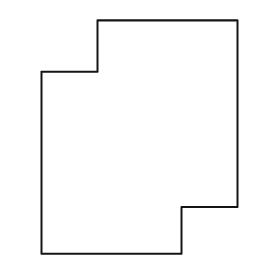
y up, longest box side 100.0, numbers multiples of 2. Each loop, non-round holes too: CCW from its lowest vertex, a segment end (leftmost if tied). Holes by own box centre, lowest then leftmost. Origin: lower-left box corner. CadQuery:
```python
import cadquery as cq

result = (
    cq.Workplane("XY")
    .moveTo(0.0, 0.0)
    .lineTo(60.0, 0.0)
    .lineTo(60.0, 20.0)
    .lineTo(84.0, 20.0)
    .lineTo(84.0, 100.0)
    .lineTo(24.0, 100.0)
    .lineTo(24.0, 78.0)
    .lineTo(0.0, 78.0)
    .close()
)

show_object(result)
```